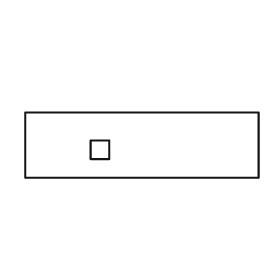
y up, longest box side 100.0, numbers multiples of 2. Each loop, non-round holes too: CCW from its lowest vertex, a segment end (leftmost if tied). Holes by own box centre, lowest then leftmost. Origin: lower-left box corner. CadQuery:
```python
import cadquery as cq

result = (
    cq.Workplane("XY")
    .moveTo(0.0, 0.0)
    .lineTo(100.0, 0.0)
    .lineTo(100.0, 28.0)
    .lineTo(0.0, 28.0)
    .close()
    .moveTo(28.0, 8.0)
    .lineTo(36.0, 8.0)
    .lineTo(36.0, 16.0)
    .lineTo(28.0, 16.0)
    .close()
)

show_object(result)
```